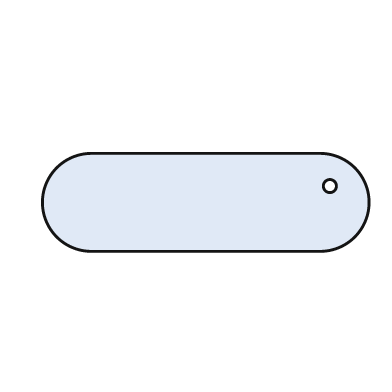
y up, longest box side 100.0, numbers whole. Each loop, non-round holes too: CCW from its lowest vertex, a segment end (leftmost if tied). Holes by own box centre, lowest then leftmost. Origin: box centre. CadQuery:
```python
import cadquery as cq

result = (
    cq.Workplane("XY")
    .moveTo(-35.0, -15.0)
    .lineTo(35.0, -15.0)
    .threePointArc((50.0, 0.0), (35.0, 15.0))
    .lineTo(-35.0, 15.0)
    .threePointArc((-50.0, 0.0), (-35.0, -15.0))
    .close()
    .moveTo(38.0, 5.0)
    .circle(2.0)
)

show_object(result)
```